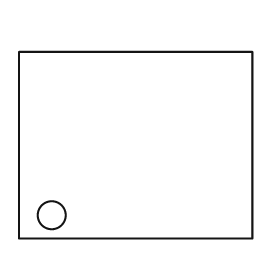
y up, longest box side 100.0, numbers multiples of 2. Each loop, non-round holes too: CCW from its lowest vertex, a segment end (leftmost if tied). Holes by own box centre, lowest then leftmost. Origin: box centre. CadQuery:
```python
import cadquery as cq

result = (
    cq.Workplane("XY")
    .moveTo(-50.0, -40.0)
    .lineTo(50.0, -40.0)
    .lineTo(50.0, 40.0)
    .lineTo(-50.0, 40.0)
    .close()
    .moveTo(-36.0, -30.0)
    .circle(6.0)
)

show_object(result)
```